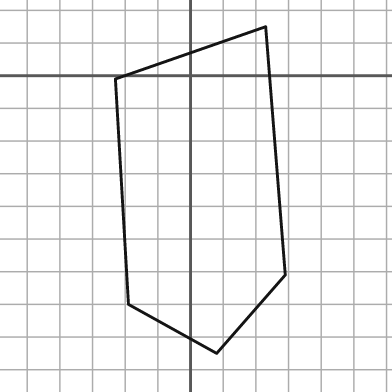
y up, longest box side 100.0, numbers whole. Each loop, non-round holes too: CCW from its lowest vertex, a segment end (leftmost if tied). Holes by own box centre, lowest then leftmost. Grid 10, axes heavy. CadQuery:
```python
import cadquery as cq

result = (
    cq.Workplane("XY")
    .moveTo(8.0, -85.0)
    .lineTo(29.0, -61.0)
    .lineTo(23.0, 15.0)
    .lineTo(-23.0, -1.0)
    .lineTo(-19.0, -70.0)
    .close()
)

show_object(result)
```